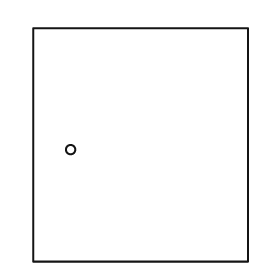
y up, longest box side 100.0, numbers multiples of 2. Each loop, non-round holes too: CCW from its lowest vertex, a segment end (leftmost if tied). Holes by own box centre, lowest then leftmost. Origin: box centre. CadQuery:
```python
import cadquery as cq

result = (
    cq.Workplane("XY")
    .moveTo(-46.0, -50.0)
    .lineTo(46.0, -50.0)
    .lineTo(46.0, 50.0)
    .lineTo(-46.0, 50.0)
    .close()
    .moveTo(-30.0, -2.0)
    .circle(2.0)
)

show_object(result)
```